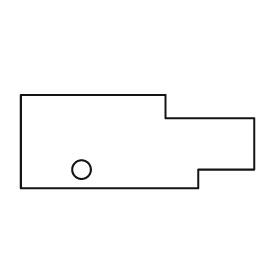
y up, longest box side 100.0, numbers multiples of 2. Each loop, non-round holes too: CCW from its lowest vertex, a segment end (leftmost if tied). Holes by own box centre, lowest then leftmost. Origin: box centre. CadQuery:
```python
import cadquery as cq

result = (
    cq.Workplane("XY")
    .moveTo(-50.0, -20.0)
    .lineTo(26.0, -20.0)
    .lineTo(26.0, -12.0)
    .lineTo(50.0, -12.0)
    .lineTo(50.0, 10.0)
    .lineTo(12.0, 10.0)
    .lineTo(12.0, 20.0)
    .lineTo(-50.0, 20.0)
    .close()
    .moveTo(-24.0, -12.0)
    .circle(4.0)
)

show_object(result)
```